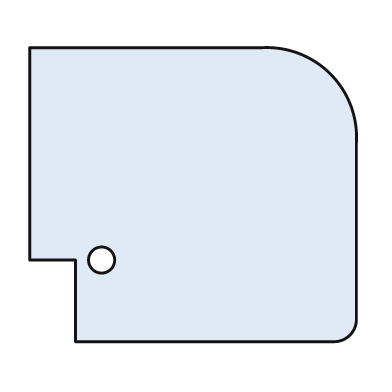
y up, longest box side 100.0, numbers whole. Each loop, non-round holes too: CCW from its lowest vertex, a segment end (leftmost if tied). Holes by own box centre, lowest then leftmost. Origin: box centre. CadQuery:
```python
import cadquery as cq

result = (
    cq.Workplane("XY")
    .moveTo(-36.0, -45.0)
    .lineTo(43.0, -45.0)
    .threePointArc((48.0, -43.0), (50.0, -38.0))
    .lineTo(50.0, 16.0)
    .threePointArc((42.0, 37.0), (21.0, 45.0))
    .lineTo(-50.0, 45.0)
    .lineTo(-50.0, -20.0)
    .lineTo(-36.0, -20.0)
    .close()
    .moveTo(-28.0, -20.0)
    .circle(4.0)
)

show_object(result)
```